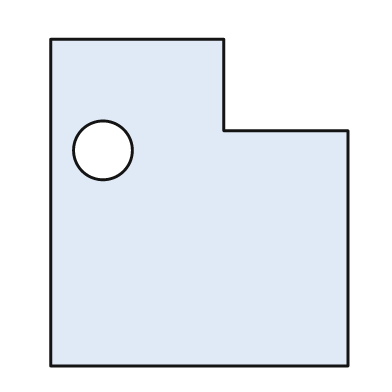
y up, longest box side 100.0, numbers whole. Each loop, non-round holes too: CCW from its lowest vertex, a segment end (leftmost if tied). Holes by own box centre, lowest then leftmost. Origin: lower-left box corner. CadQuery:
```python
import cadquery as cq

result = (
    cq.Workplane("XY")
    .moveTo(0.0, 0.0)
    .lineTo(91.0, 0.0)
    .lineTo(91.0, 72.0)
    .lineTo(53.0, 72.0)
    .lineTo(53.0, 100.0)
    .lineTo(0.0, 100.0)
    .close()
    .moveTo(16.0, 66.0)
    .circle(9.0)
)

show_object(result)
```